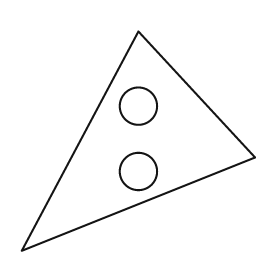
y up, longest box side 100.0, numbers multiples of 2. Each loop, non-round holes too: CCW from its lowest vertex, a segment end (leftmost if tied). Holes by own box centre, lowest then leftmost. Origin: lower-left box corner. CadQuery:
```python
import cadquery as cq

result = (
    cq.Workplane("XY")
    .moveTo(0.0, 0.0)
    .lineTo(100.0, 40.0)
    .lineTo(50.0, 94.0)
    .close()
    .moveTo(50.0, 34.0)
    .circle(8.0)
    .moveTo(50.0, 62.0)
    .circle(8.0)
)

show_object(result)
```